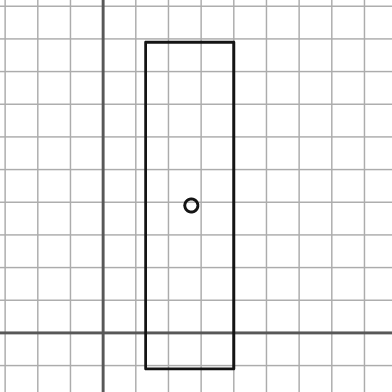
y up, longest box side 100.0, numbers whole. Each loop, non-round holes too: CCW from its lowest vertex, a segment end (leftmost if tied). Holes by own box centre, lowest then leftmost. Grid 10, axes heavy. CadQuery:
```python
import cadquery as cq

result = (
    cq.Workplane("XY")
    .moveTo(13.0, -11.0)
    .lineTo(40.0, -11.0)
    .lineTo(40.0, 89.0)
    .lineTo(13.0, 89.0)
    .close()
    .moveTo(27.0, 39.0)
    .circle(2.0)
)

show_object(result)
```